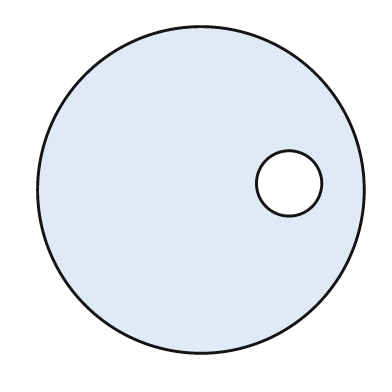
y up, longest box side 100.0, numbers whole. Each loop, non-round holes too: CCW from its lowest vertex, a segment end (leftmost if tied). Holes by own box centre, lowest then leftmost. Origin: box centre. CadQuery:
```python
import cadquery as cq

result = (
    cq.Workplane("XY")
    .moveTo(0.0, 0.0)
    .circle(50.0)
    .moveTo(27.0, 2.0)
    .circle(10.0)
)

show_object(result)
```